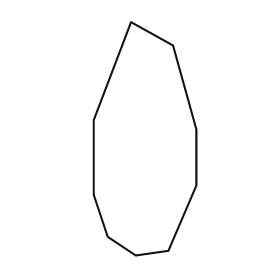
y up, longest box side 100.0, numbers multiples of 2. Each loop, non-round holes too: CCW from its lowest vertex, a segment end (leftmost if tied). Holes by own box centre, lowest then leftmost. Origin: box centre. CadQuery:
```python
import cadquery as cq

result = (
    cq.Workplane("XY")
    .moveTo(-4.0, -50.0)
    .lineTo(10.0, -48.0)
    .lineTo(22.0, -20.0)
    .lineTo(22.0, 4.0)
    .lineTo(12.0, 40.0)
    .lineTo(-6.0, 50.0)
    .lineTo(-22.0, 8.0)
    .lineTo(-22.0, -24.0)
    .lineTo(-16.0, -42.0)
    .close()
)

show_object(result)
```